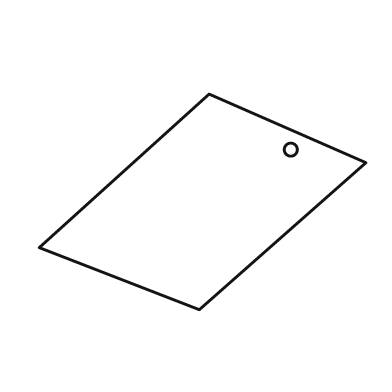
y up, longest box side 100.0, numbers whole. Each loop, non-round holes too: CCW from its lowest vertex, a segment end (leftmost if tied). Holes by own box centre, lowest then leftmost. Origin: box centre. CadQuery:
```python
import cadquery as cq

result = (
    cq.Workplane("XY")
    .moveTo(-1.0, -33.0)
    .lineTo(50.0, 12.0)
    .lineTo(2.0, 33.0)
    .lineTo(-50.0, -14.0)
    .close()
    .moveTo(27.0, 16.0)
    .circle(2.0)
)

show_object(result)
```